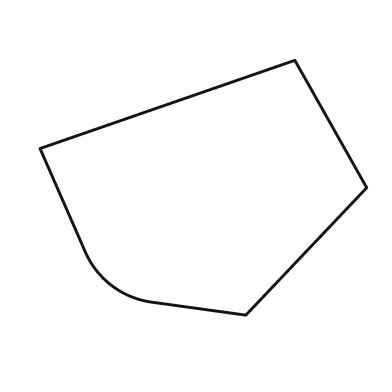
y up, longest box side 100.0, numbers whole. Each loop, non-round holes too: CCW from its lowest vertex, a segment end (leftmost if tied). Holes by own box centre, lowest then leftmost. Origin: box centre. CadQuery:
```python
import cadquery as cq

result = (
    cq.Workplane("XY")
    .moveTo(13.0, -39.0)
    .lineTo(50.0, 0.0)
    .lineTo(28.0, 39.0)
    .lineTo(-50.0, 12.0)
    .lineTo(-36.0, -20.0)
    .threePointArc((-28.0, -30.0), (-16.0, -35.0))
    .close()
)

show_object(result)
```